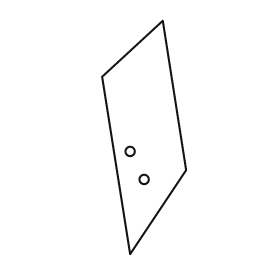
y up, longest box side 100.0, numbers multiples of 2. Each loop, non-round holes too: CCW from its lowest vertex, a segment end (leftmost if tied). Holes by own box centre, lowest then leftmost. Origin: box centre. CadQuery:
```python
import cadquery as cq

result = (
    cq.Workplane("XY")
    .moveTo(-6.0, -50.0)
    .lineTo(18.0, -14.0)
    .lineTo(8.0, 50.0)
    .lineTo(-18.0, 26.0)
    .close()
    .moveTo(0.0, -18.0)
    .circle(2.0)
    .moveTo(-6.0, -6.0)
    .circle(2.0)
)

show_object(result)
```